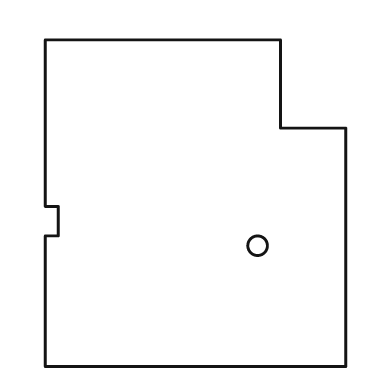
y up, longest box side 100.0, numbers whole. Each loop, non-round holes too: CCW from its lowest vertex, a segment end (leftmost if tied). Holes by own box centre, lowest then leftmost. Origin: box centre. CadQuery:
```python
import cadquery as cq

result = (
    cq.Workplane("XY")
    .moveTo(-46.0, -50.0)
    .lineTo(46.0, -50.0)
    .lineTo(46.0, 23.0)
    .lineTo(26.0, 23.0)
    .lineTo(26.0, 50.0)
    .lineTo(-46.0, 50.0)
    .lineTo(-46.0, -1.0)
    .lineTo(-42.0, -1.0)
    .lineTo(-42.0, -10.0)
    .lineTo(-46.0, -10.0)
    .close()
    .moveTo(19.0, -13.0)
    .circle(3.0)
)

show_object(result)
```